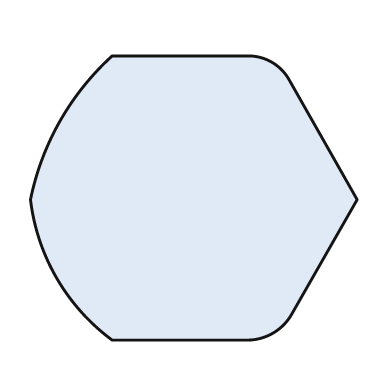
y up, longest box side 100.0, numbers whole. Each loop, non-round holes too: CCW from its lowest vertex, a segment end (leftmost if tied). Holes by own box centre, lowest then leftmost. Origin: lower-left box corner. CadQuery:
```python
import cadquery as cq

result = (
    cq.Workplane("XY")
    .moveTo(25.0, 0.0)
    .lineTo(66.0, 0.0)
    .threePointArc((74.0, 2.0), (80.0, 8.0))
    .lineTo(100.0, 43.0)
    .lineTo(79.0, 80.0)
    .threePointArc((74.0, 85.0), (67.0, 87.0))
    .lineTo(25.0, 87.0)
    .threePointArc((9.0, 67.0), (0.0, 43.0))
    .threePointArc((8.0, 19.0), (25.0, 0.0))
    .close()
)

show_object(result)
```